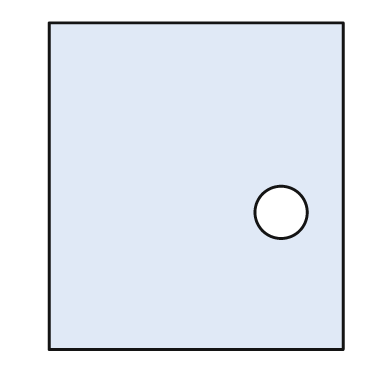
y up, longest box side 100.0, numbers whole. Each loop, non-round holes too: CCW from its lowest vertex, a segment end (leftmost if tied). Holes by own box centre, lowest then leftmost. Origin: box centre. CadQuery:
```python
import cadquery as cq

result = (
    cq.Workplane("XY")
    .moveTo(-45.0, -50.0)
    .lineTo(45.0, -50.0)
    .lineTo(45.0, 50.0)
    .lineTo(-45.0, 50.0)
    .close()
    .moveTo(26.0, -8.0)
    .circle(8.0)
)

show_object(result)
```